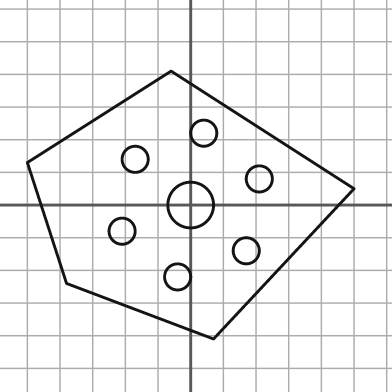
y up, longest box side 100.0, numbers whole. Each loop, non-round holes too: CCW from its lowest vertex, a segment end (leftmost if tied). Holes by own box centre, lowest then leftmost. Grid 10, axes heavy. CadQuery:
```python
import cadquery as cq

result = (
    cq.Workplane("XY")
    .moveTo(7.0, -41.0)
    .lineTo(50.0, 5.0)
    .lineTo(-6.0, 41.0)
    .lineTo(-50.0, 13.0)
    .lineTo(-38.0, -24.0)
    .close()
    .moveTo(-4.0, -22.0)
    .circle(4.0)
    .moveTo(17.0, -14.0)
    .circle(4.0)
    .moveTo(-21.0, -8.0)
    .circle(4.0)
    .moveTo(0.0, 0.0)
    .circle(7.0)
    .moveTo(21.0, 8.0)
    .circle(4.0)
    .moveTo(-17.0, 14.0)
    .circle(4.0)
    .moveTo(4.0, 22.0)
    .circle(4.0)
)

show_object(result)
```